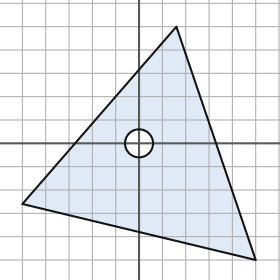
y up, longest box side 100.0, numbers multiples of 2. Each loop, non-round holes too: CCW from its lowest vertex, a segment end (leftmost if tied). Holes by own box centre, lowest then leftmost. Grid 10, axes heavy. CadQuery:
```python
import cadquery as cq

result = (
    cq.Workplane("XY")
    .moveTo(50.0, -50.0)
    .lineTo(16.0, 50.0)
    .lineTo(-50.0, -26.0)
    .close()
    .moveTo(0.0, 0.0)
    .circle(6.0)
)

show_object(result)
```